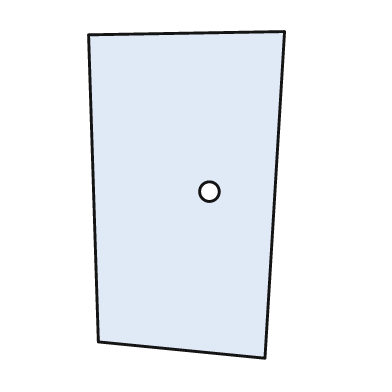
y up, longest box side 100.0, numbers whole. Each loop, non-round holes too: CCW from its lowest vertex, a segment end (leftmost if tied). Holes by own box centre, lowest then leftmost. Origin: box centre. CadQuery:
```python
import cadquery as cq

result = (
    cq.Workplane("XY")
    .moveTo(24.0, -50.0)
    .lineTo(30.0, 50.0)
    .lineTo(-30.0, 49.0)
    .lineTo(-27.0, -45.0)
    .close()
    .moveTo(7.0, 1.0)
    .circle(3.0)
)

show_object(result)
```